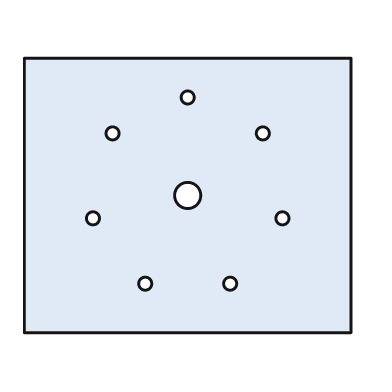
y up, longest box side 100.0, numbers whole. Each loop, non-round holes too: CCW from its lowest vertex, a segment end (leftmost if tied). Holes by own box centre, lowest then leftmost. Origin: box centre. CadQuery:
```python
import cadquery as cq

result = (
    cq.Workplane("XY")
    .moveTo(-50.0, -42.0)
    .lineTo(50.0, -42.0)
    .lineTo(50.0, 42.0)
    .lineTo(-50.0, 42.0)
    .close()
    .moveTo(-13.0, -27.0)
    .circle(2.0)
    .moveTo(13.0, -27.0)
    .circle(2.0)
    .moveTo(-29.0, -7.0)
    .circle(2.0)
    .moveTo(29.0, -7.0)
    .circle(2.0)
    .moveTo(0.0, 0.0)
    .circle(4.0)
    .moveTo(-23.0, 19.0)
    .circle(2.0)
    .moveTo(23.0, 19.0)
    .circle(2.0)
    .moveTo(0.0, 30.0)
    .circle(2.0)
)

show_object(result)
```